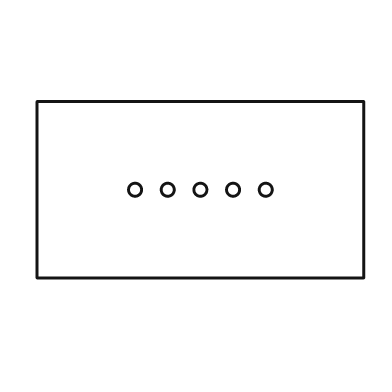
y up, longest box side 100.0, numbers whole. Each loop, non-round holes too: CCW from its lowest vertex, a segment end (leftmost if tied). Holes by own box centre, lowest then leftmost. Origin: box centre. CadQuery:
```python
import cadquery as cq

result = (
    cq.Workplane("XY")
    .moveTo(-50.0, -27.0)
    .lineTo(50.0, -27.0)
    .lineTo(50.0, 27.0)
    .lineTo(-50.0, 27.0)
    .close()
    .moveTo(-20.0, 0.0)
    .circle(2.0)
    .moveTo(-10.0, 0.0)
    .circle(2.0)
    .moveTo(0.0, 0.0)
    .circle(2.0)
    .moveTo(10.0, 0.0)
    .circle(2.0)
    .moveTo(20.0, 0.0)
    .circle(2.0)
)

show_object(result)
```